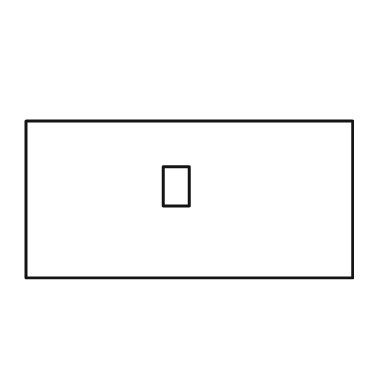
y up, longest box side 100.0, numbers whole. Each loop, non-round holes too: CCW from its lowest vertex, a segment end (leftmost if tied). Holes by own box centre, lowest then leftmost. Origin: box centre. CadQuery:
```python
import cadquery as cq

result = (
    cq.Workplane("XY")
    .moveTo(-50.0, -24.0)
    .lineTo(50.0, -24.0)
    .lineTo(50.0, 24.0)
    .lineTo(-50.0, 24.0)
    .close()
    .moveTo(-8.0, -2.0)
    .lineTo(0.0, -2.0)
    .lineTo(0.0, 10.0)
    .lineTo(-8.0, 10.0)
    .close()
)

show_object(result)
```